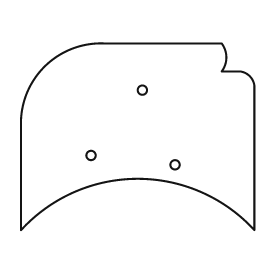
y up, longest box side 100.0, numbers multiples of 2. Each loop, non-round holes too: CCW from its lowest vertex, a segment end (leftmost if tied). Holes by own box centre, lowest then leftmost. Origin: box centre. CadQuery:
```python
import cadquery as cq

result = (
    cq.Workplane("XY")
    .moveTo(-50.0, -40.0)
    .threePointArc((0.0, -18.0), (50.0, -40.0))
    .lineTo(50.0, 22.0)
    .threePointArc((48.0, 26.0), (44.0, 28.0))
    .lineTo(36.0, 28.0)
    .threePointArc((38.0, 34.0), (36.0, 40.0))
    .lineTo(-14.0, 40.0)
    .threePointArc((-40.0, 30.0), (-50.0, 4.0))
    .close()
    .moveTo(16.0, -12.0)
    .circle(2.0)
    .moveTo(-20.0, -8.0)
    .circle(2.0)
    .moveTo(2.0, 20.0)
    .circle(2.0)
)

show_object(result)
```